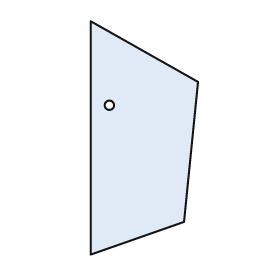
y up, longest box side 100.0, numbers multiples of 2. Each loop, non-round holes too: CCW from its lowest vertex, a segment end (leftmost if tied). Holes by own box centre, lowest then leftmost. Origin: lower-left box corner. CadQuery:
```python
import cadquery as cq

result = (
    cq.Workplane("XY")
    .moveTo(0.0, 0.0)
    .lineTo(40.0, 14.0)
    .lineTo(46.0, 74.0)
    .lineTo(0.0, 100.0)
    .close()
    .moveTo(8.0, 64.0)
    .circle(2.0)
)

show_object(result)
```